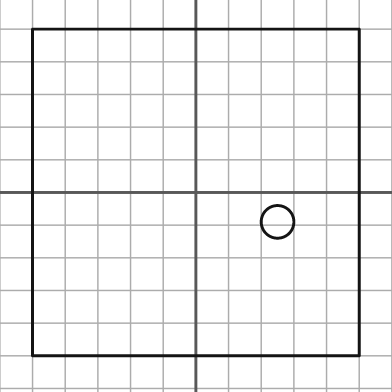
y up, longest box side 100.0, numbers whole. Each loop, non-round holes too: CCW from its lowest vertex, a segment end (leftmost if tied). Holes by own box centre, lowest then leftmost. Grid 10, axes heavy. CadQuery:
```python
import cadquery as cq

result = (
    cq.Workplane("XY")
    .moveTo(-50.0, -50.0)
    .lineTo(50.0, -50.0)
    .lineTo(50.0, 50.0)
    .lineTo(-50.0, 50.0)
    .close()
    .moveTo(25.0, -9.0)
    .circle(5.0)
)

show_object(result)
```